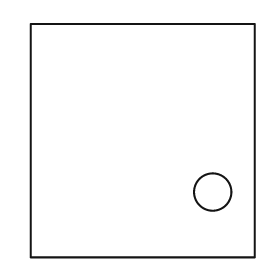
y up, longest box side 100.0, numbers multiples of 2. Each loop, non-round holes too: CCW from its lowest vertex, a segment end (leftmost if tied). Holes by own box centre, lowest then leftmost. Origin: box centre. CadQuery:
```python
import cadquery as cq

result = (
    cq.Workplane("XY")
    .moveTo(-48.0, -50.0)
    .lineTo(48.0, -50.0)
    .lineTo(48.0, 50.0)
    .lineTo(-48.0, 50.0)
    .close()
    .moveTo(30.0, -22.0)
    .circle(8.0)
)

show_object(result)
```